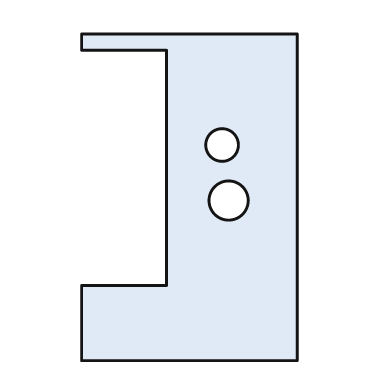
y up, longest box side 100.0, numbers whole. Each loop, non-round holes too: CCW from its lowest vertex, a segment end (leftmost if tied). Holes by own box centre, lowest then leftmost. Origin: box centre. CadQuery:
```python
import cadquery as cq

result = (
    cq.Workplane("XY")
    .moveTo(-33.0, -50.0)
    .lineTo(33.0, -50.0)
    .lineTo(33.0, 50.0)
    .lineTo(-33.0, 50.0)
    .lineTo(-33.0, 45.0)
    .lineTo(-7.0, 45.0)
    .lineTo(-7.0, -27.0)
    .lineTo(-33.0, -27.0)
    .close()
    .moveTo(12.0, -1.0)
    .circle(6.0)
    .moveTo(10.0, 16.0)
    .circle(5.0)
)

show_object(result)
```